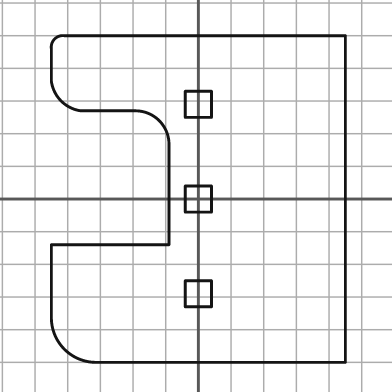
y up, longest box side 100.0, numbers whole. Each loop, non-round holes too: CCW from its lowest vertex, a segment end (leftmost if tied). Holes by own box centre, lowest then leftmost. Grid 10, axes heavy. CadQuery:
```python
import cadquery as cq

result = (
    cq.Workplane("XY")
    .moveTo(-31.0, -50.0)
    .lineTo(45.0, -50.0)
    .lineTo(45.0, 50.0)
    .lineTo(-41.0, 50.0)
    .threePointArc((-44.0, 49.0), (-45.0, 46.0))
    .lineTo(-45.0, 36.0)
    .threePointArc((-42.0, 30.0), (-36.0, 27.0))
    .lineTo(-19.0, 27.0)
    .threePointArc((-12.0, 24.0), (-9.0, 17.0))
    .lineTo(-9.0, -14.0)
    .lineTo(-45.0, -14.0)
    .lineTo(-45.0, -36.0)
    .threePointArc((-41.0, -46.0), (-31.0, -50.0))
    .close()
    .moveTo(-4.0, -33.0)
    .lineTo(4.0, -33.0)
    .lineTo(4.0, -25.0)
    .lineTo(-4.0, -25.0)
    .close()
    .moveTo(-4.0, -4.0)
    .lineTo(4.0, -4.0)
    .lineTo(4.0, 4.0)
    .lineTo(-4.0, 4.0)
    .close()
    .moveTo(-4.0, 25.0)
    .lineTo(4.0, 25.0)
    .lineTo(4.0, 33.0)
    .lineTo(-4.0, 33.0)
    .close()
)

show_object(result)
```